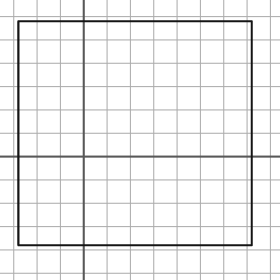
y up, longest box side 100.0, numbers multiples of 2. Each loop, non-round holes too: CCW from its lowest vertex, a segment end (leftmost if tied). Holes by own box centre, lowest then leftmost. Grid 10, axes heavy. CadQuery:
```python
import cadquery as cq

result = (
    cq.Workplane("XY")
    .moveTo(-28.0, -38.0)
    .lineTo(72.0, -38.0)
    .lineTo(72.0, 58.0)
    .lineTo(-28.0, 58.0)
    .close()
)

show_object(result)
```